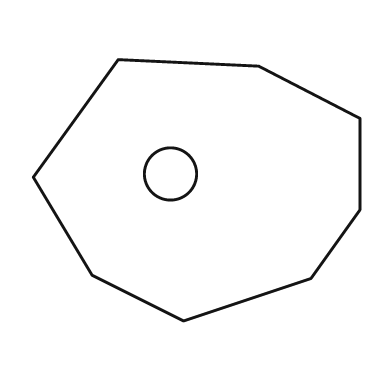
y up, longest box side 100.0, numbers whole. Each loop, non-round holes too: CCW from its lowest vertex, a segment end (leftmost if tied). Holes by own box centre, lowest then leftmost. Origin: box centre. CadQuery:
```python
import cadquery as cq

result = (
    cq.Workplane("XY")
    .moveTo(-4.0, -40.0)
    .lineTo(35.0, -27.0)
    .lineTo(50.0, -6.0)
    .lineTo(50.0, 22.0)
    .lineTo(19.0, 38.0)
    .lineTo(-24.0, 40.0)
    .lineTo(-50.0, 4.0)
    .lineTo(-32.0, -26.0)
    .close()
    .moveTo(-8.0, 5.0)
    .circle(8.0)
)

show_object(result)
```